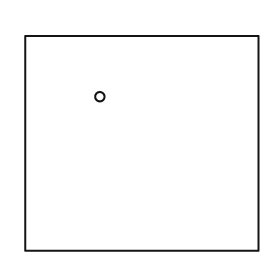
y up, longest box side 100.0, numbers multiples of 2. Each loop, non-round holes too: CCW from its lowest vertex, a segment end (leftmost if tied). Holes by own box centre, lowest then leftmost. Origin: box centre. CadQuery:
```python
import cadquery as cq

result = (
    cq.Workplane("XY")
    .moveTo(-50.0, -46.0)
    .lineTo(50.0, -46.0)
    .lineTo(50.0, 46.0)
    .lineTo(-50.0, 46.0)
    .close()
    .moveTo(-18.0, 20.0)
    .circle(2.0)
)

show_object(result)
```